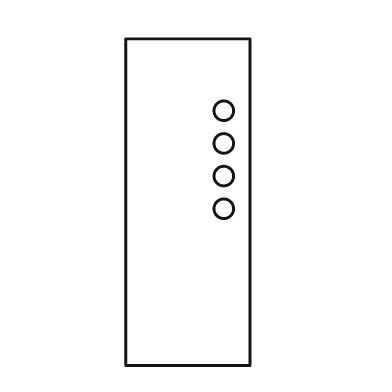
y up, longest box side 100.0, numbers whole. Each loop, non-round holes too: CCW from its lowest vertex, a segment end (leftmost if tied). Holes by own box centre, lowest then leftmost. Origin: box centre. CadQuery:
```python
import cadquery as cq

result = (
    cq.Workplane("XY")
    .moveTo(-19.0, -50.0)
    .lineTo(19.0, -50.0)
    .lineTo(19.0, 50.0)
    .lineTo(-19.0, 50.0)
    .close()
    .moveTo(11.0, -2.0)
    .circle(3.0)
    .moveTo(11.0, 8.0)
    .circle(3.0)
    .moveTo(11.0, 18.0)
    .circle(3.0)
    .moveTo(11.0, 28.0)
    .circle(3.0)
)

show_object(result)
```